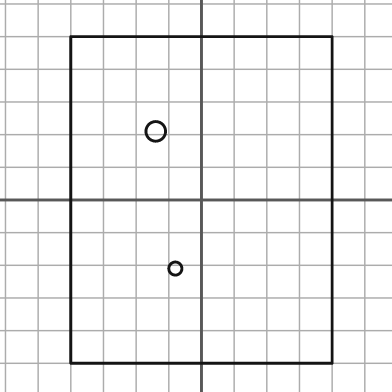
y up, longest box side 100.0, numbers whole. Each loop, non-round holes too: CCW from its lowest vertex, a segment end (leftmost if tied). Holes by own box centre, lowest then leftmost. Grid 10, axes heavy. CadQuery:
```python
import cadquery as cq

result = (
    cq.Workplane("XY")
    .moveTo(-40.0, -50.0)
    .lineTo(40.0, -50.0)
    .lineTo(40.0, 50.0)
    .lineTo(-40.0, 50.0)
    .close()
    .moveTo(-8.0, -21.0)
    .circle(2.0)
    .moveTo(-14.0, 21.0)
    .circle(3.0)
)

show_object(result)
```